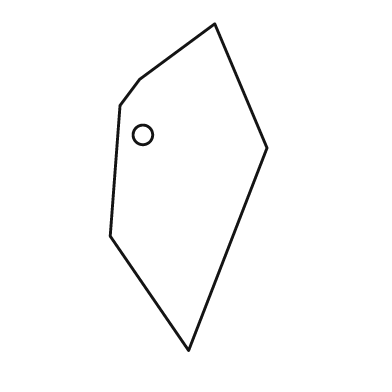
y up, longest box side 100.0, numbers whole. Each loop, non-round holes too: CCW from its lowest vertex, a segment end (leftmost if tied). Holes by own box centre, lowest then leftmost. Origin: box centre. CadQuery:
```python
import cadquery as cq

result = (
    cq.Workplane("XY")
    .moveTo(0.0, -50.0)
    .lineTo(24.0, 12.0)
    .lineTo(8.0, 50.0)
    .lineTo(-15.0, 33.0)
    .lineTo(-21.0, 25.0)
    .lineTo(-24.0, -15.0)
    .close()
    .moveTo(-14.0, 16.0)
    .circle(3.0)
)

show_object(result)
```